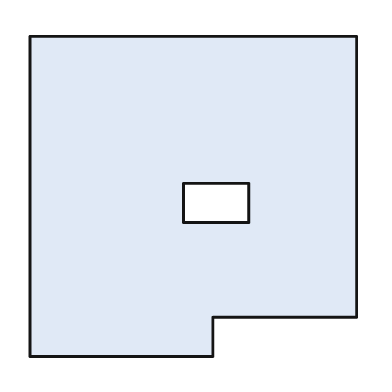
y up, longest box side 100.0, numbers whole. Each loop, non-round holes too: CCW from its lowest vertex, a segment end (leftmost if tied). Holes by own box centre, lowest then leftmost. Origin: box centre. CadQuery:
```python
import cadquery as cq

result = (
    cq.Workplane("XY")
    .moveTo(-50.0, -49.0)
    .lineTo(6.0, -49.0)
    .lineTo(6.0, -37.0)
    .lineTo(50.0, -37.0)
    .lineTo(50.0, 49.0)
    .lineTo(-50.0, 49.0)
    .close()
    .moveTo(-3.0, -8.0)
    .lineTo(17.0, -8.0)
    .lineTo(17.0, 4.0)
    .lineTo(-3.0, 4.0)
    .close()
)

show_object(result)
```